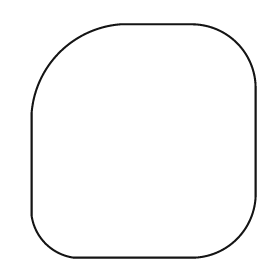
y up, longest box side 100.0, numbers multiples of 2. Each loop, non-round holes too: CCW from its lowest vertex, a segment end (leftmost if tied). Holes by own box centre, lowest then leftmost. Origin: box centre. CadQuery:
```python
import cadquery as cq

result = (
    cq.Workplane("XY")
    .moveTo(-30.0, -50.0)
    .lineTo(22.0, -50.0)
    .threePointArc((40.0, -42.0), (48.0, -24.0))
    .lineTo(48.0, 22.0)
    .threePointArc((40.0, 42.0), (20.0, 50.0))
    .lineTo(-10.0, 50.0)
    .threePointArc((-36.0, 38.0), (-48.0, 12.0))
    .lineTo(-48.0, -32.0)
    .threePointArc((-42.0, -44.0), (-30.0, -50.0))
    .close()
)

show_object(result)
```